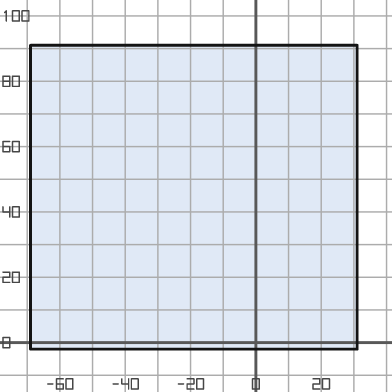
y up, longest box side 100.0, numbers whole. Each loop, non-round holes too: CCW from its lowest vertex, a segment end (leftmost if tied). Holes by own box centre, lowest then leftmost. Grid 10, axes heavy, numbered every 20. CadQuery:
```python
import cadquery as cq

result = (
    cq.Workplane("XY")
    .moveTo(-69.0, -2.0)
    .lineTo(31.0, -2.0)
    .lineTo(31.0, 91.0)
    .lineTo(-69.0, 91.0)
    .close()
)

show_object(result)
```